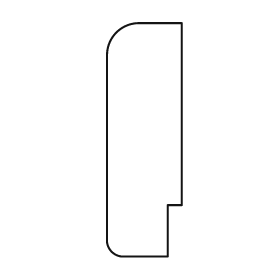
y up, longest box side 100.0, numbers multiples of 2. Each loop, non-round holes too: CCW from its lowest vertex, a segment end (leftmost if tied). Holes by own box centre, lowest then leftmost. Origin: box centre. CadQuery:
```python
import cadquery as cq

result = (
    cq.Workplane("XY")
    .moveTo(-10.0, -50.0)
    .lineTo(10.0, -50.0)
    .lineTo(10.0, -28.0)
    .lineTo(16.0, -28.0)
    .lineTo(16.0, 50.0)
    .lineTo(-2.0, 50.0)
    .threePointArc((-12.0, 46.0), (-16.0, 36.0))
    .lineTo(-16.0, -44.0)
    .threePointArc((-14.0, -48.0), (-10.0, -50.0))
    .close()
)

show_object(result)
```